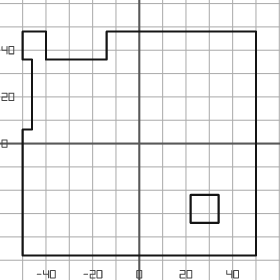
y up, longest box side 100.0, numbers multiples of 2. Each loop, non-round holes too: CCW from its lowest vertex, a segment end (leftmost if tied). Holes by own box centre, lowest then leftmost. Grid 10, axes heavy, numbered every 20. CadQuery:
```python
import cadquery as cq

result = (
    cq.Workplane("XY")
    .moveTo(-50.0, -48.0)
    .lineTo(50.0, -48.0)
    .lineTo(50.0, 48.0)
    .lineTo(-14.0, 48.0)
    .lineTo(-14.0, 36.0)
    .lineTo(-40.0, 36.0)
    .lineTo(-40.0, 48.0)
    .lineTo(-50.0, 48.0)
    .lineTo(-50.0, 36.0)
    .lineTo(-46.0, 36.0)
    .lineTo(-46.0, 6.0)
    .lineTo(-50.0, 6.0)
    .close()
    .moveTo(22.0, -34.0)
    .lineTo(34.0, -34.0)
    .lineTo(34.0, -22.0)
    .lineTo(22.0, -22.0)
    .close()
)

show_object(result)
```